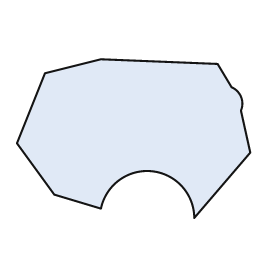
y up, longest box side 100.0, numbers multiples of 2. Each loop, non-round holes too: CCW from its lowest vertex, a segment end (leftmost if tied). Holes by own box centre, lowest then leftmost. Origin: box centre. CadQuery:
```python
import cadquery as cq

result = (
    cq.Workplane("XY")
    .moveTo(26.0, -34.0)
    .lineTo(50.0, -6.0)
    .lineTo(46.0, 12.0)
    .threePointArc((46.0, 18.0), (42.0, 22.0))
    .lineTo(36.0, 32.0)
    .lineTo(-14.0, 34.0)
    .lineTo(-38.0, 28.0)
    .lineTo(-50.0, -2.0)
    .lineTo(-34.0, -24.0)
    .lineTo(-14.0, -30.0)
    .threePointArc((8.0, -14.0), (26.0, -34.0))
    .close()
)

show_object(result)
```